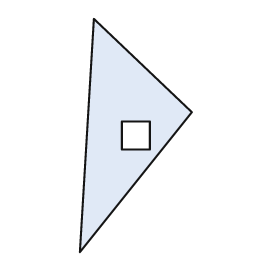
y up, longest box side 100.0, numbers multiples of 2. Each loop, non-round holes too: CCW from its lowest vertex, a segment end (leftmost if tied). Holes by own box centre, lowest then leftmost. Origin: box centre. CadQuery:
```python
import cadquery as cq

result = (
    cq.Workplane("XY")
    .moveTo(-24.0, -50.0)
    .lineTo(24.0, 10.0)
    .lineTo(-18.0, 50.0)
    .close()
    .moveTo(-6.0, -6.0)
    .lineTo(6.0, -6.0)
    .lineTo(6.0, 6.0)
    .lineTo(-6.0, 6.0)
    .close()
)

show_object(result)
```